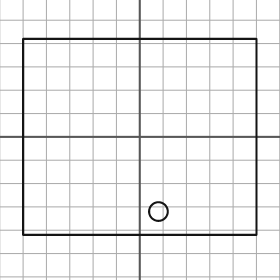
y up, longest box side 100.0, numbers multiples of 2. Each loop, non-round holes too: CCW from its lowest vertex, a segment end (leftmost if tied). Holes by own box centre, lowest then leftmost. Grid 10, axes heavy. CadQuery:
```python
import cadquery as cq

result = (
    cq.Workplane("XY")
    .moveTo(-50.0, -42.0)
    .lineTo(50.0, -42.0)
    .lineTo(50.0, 42.0)
    .lineTo(-50.0, 42.0)
    .close()
    .moveTo(8.0, -32.0)
    .circle(4.0)
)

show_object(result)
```